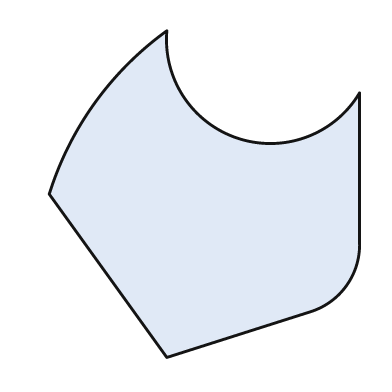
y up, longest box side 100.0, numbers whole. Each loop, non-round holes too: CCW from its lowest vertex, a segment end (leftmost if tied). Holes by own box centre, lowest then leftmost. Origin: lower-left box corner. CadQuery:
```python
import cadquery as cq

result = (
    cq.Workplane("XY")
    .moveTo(36.0, 0.0)
    .lineTo(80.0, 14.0)
    .threePointArc((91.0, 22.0), (95.0, 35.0))
    .lineTo(95.0, 81.0)
    .threePointArc((58.0, 67.0), (36.0, 100.0))
    .threePointArc((14.0, 78.0), (0.0, 50.0))
    .close()
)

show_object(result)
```